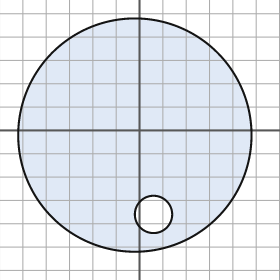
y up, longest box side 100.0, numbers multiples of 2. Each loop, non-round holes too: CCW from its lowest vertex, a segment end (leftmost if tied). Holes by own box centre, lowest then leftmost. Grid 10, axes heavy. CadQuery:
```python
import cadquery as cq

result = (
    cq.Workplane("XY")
    .moveTo(-2.0, -2.0)
    .circle(50.0)
    .moveTo(6.0, -36.0)
    .circle(8.0)
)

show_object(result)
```